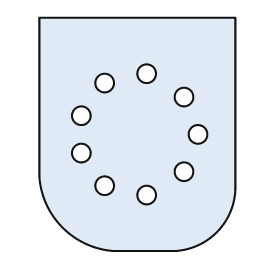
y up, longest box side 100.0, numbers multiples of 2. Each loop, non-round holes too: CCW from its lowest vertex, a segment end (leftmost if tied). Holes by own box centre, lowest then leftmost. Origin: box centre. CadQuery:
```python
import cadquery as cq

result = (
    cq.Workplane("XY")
    .moveTo(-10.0, -50.0)
    .lineTo(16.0, -50.0)
    .threePointArc((34.0, -42.0), (42.0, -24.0))
    .lineTo(42.0, 50.0)
    .lineTo(-42.0, 50.0)
    .lineTo(-42.0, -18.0)
    .threePointArc((-32.0, -40.0), (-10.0, -50.0))
    .close()
    .moveTo(4.0, -26.0)
    .circle(4.0)
    .moveTo(-14.0, -22.0)
    .circle(4.0)
    .moveTo(20.0, -16.0)
    .circle(4.0)
    .moveTo(-24.0, -8.0)
    .circle(4.0)
    .moveTo(26.0, 0.0)
    .circle(4.0)
    .moveTo(-24.0, 8.0)
    .circle(4.0)
    .moveTo(20.0, 16.0)
    .circle(4.0)
    .moveTo(-14.0, 22.0)
    .circle(4.0)
    .moveTo(4.0, 26.0)
    .circle(4.0)
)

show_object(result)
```